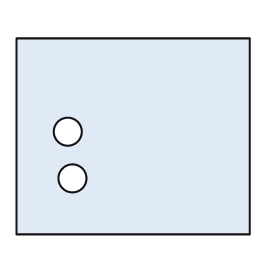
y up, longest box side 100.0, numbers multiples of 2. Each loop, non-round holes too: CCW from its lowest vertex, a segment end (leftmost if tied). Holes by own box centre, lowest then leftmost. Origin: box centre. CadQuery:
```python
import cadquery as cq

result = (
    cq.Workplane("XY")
    .moveTo(-50.0, -42.0)
    .lineTo(50.0, -42.0)
    .lineTo(50.0, 42.0)
    .lineTo(-50.0, 42.0)
    .close()
    .moveTo(-26.0, -18.0)
    .circle(6.0)
    .moveTo(-28.0, 2.0)
    .circle(6.0)
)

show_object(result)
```